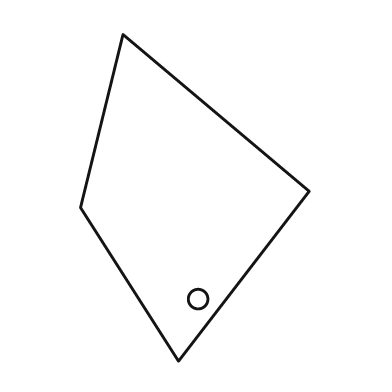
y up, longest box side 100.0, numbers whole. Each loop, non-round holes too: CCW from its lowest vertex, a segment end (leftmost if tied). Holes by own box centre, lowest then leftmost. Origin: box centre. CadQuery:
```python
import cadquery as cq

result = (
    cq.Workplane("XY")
    .moveTo(-5.0, -50.0)
    .lineTo(35.0, 2.0)
    .lineTo(-22.0, 50.0)
    .lineTo(-35.0, -3.0)
    .close()
    .moveTo(1.0, -31.0)
    .circle(3.0)
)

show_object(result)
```